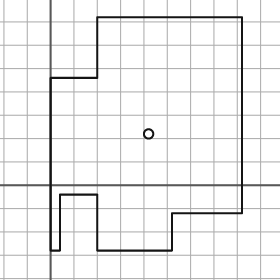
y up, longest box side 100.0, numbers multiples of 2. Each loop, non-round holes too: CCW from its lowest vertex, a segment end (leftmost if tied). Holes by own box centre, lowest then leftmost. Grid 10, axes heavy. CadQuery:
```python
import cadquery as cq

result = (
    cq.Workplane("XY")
    .moveTo(0.0, -28.0)
    .lineTo(4.0, -28.0)
    .lineTo(4.0, -4.0)
    .lineTo(20.0, -4.0)
    .lineTo(20.0, -28.0)
    .lineTo(52.0, -28.0)
    .lineTo(52.0, -12.0)
    .lineTo(82.0, -12.0)
    .lineTo(82.0, 72.0)
    .lineTo(20.0, 72.0)
    .lineTo(20.0, 46.0)
    .lineTo(0.0, 46.0)
    .close()
    .moveTo(42.0, 22.0)
    .circle(2.0)
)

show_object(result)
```